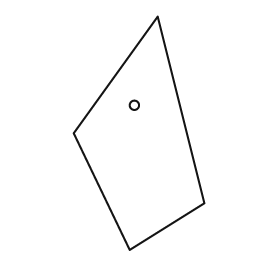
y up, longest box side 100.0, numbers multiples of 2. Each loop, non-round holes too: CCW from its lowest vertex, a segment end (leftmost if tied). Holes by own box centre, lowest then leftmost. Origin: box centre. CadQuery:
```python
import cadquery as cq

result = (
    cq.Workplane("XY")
    .moveTo(-4.0, -50.0)
    .lineTo(28.0, -30.0)
    .lineTo(8.0, 50.0)
    .lineTo(-28.0, 0.0)
    .close()
    .moveTo(-2.0, 12.0)
    .circle(2.0)
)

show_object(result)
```